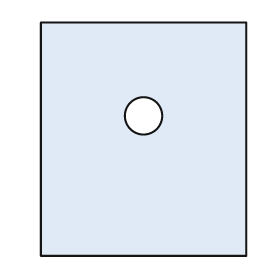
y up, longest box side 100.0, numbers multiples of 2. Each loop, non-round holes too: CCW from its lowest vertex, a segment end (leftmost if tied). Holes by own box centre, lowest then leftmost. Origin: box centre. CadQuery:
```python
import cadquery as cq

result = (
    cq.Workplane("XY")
    .moveTo(-44.0, -50.0)
    .lineTo(44.0, -50.0)
    .lineTo(44.0, 50.0)
    .lineTo(-44.0, 50.0)
    .close()
    .moveTo(0.0, 10.0)
    .circle(8.0)
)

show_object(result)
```